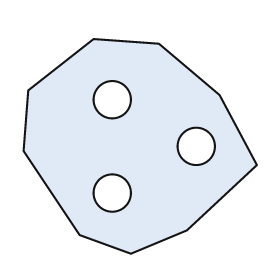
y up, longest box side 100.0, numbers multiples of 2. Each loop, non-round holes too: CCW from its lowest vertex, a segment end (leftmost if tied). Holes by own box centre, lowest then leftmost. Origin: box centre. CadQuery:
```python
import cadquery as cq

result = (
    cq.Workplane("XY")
    .moveTo(-4.0, -46.0)
    .lineTo(20.0, -36.0)
    .lineTo(50.0, -8.0)
    .lineTo(34.0, 22.0)
    .lineTo(8.0, 44.0)
    .lineTo(-20.0, 46.0)
    .lineTo(-48.0, 24.0)
    .lineTo(-50.0, -2.0)
    .lineTo(-26.0, -38.0)
    .close()
    .moveTo(-12.0, -20.0)
    .circle(8.0)
    .moveTo(24.0, 0.0)
    .circle(8.0)
    .moveTo(-12.0, 20.0)
    .circle(8.0)
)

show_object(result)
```